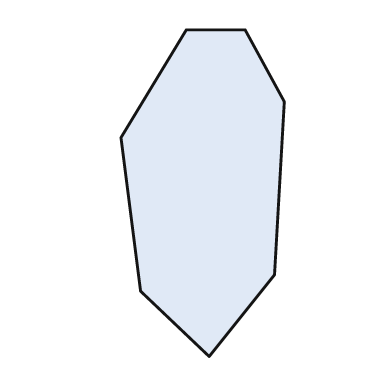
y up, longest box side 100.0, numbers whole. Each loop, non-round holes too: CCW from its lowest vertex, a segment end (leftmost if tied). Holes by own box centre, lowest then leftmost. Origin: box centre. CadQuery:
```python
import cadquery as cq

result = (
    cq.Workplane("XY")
    .moveTo(2.0, -50.0)
    .lineTo(22.0, -25.0)
    .lineTo(25.0, 28.0)
    .lineTo(13.0, 50.0)
    .lineTo(-5.0, 50.0)
    .lineTo(-25.0, 17.0)
    .lineTo(-19.0, -30.0)
    .close()
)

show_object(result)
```